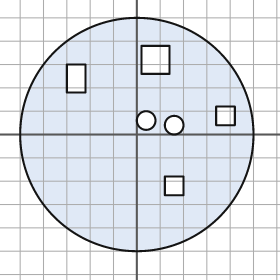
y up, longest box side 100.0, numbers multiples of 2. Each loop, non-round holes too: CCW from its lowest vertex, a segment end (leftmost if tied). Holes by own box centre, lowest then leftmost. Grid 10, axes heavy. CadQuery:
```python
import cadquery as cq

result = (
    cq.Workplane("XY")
    .moveTo(0.0, 0.0)
    .circle(50.0)
    .moveTo(12.0, -26.0)
    .lineTo(20.0, -26.0)
    .lineTo(20.0, -18.0)
    .lineTo(12.0, -18.0)
    .close()
    .moveTo(16.0, 4.0)
    .circle(4.0)
    .moveTo(4.0, 6.0)
    .circle(4.0)
    .moveTo(34.0, 4.0)
    .lineTo(42.0, 4.0)
    .lineTo(42.0, 12.0)
    .lineTo(34.0, 12.0)
    .close()
    .moveTo(-30.0, 18.0)
    .lineTo(-22.0, 18.0)
    .lineTo(-22.0, 30.0)
    .lineTo(-30.0, 30.0)
    .close()
    .moveTo(2.0, 26.0)
    .lineTo(14.0, 26.0)
    .lineTo(14.0, 38.0)
    .lineTo(2.0, 38.0)
    .close()
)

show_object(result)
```